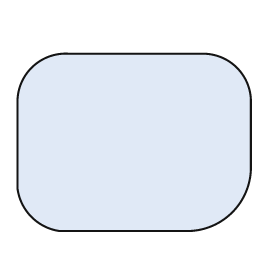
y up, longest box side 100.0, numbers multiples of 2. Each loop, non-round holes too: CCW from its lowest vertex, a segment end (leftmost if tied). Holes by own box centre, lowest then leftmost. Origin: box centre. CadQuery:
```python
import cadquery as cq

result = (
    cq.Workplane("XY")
    .moveTo(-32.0, -38.0)
    .lineTo(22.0, -38.0)
    .threePointArc((42.0, -30.0), (50.0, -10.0))
    .lineTo(50.0, 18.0)
    .threePointArc((44.0, 32.0), (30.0, 38.0))
    .lineTo(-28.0, 38.0)
    .threePointArc((-44.0, 32.0), (-50.0, 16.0))
    .lineTo(-50.0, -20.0)
    .threePointArc((-44.0, -32.0), (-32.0, -38.0))
    .close()
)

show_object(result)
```